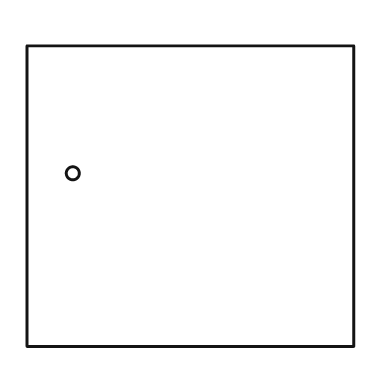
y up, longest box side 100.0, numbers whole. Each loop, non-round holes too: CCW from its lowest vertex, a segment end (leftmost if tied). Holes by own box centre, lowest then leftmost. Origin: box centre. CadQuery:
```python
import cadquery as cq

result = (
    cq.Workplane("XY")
    .moveTo(-50.0, -46.0)
    .lineTo(50.0, -46.0)
    .lineTo(50.0, 46.0)
    .lineTo(-50.0, 46.0)
    .close()
    .moveTo(-36.0, 7.0)
    .circle(2.0)
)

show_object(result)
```